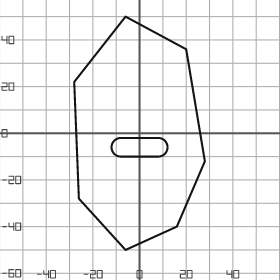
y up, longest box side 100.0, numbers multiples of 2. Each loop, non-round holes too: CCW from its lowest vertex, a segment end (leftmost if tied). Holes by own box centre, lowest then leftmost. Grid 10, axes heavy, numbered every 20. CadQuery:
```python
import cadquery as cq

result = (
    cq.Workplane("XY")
    .moveTo(-6.0, -50.0)
    .lineTo(16.0, -40.0)
    .lineTo(28.0, -12.0)
    .lineTo(20.0, 36.0)
    .lineTo(-6.0, 50.0)
    .lineTo(-28.0, 22.0)
    .lineTo(-26.0, -28.0)
    .close()
    .moveTo(-8.0, -10.0)
    .lineTo(8.0, -10.0)
    .threePointArc((12.0, -6.0), (8.0, -2.0))
    .lineTo(-8.0, -2.0)
    .threePointArc((-12.0, -6.0), (-8.0, -10.0))
    .close()
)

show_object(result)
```